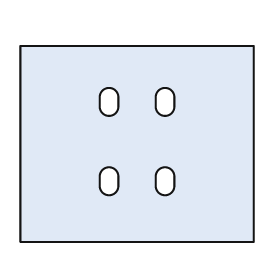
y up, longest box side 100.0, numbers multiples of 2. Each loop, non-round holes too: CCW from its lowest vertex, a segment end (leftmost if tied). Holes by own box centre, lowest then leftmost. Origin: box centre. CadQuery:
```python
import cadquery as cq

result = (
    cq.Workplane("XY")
    .moveTo(-50.0, -42.0)
    .lineTo(50.0, -42.0)
    .lineTo(50.0, 42.0)
    .lineTo(-50.0, 42.0)
    .close()
    .moveTo(-16.0, -18.0)
    .threePointArc((-12.0, -22.0), (-8.0, -18.0))
    .lineTo(-8.0, -14.0)
    .threePointArc((-12.0, -10.0), (-16.0, -14.0))
    .close()
    .moveTo(8.0, -18.0)
    .threePointArc((12.0, -22.0), (16.0, -18.0))
    .lineTo(16.0, -14.0)
    .threePointArc((12.0, -10.0), (8.0, -14.0))
    .close()
    .moveTo(-16.0, 16.0)
    .threePointArc((-12.0, 12.0), (-8.0, 16.0))
    .lineTo(-8.0, 20.0)
    .threePointArc((-12.0, 24.0), (-16.0, 20.0))
    .close()
    .moveTo(8.0, 16.0)
    .threePointArc((12.0, 12.0), (16.0, 16.0))
    .lineTo(16.0, 20.0)
    .threePointArc((12.0, 24.0), (8.0, 20.0))
    .close()
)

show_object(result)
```